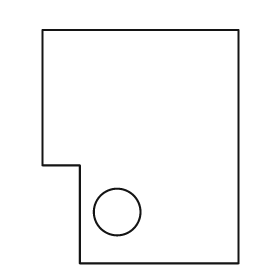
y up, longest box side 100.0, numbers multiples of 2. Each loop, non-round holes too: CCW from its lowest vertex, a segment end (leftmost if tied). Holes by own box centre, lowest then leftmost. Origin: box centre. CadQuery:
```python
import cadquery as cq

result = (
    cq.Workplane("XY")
    .moveTo(-26.0, -50.0)
    .lineTo(42.0, -50.0)
    .lineTo(42.0, 50.0)
    .lineTo(-42.0, 50.0)
    .lineTo(-42.0, -8.0)
    .lineTo(-26.0, -8.0)
    .close()
    .moveTo(-10.0, -28.0)
    .circle(10.0)
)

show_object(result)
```